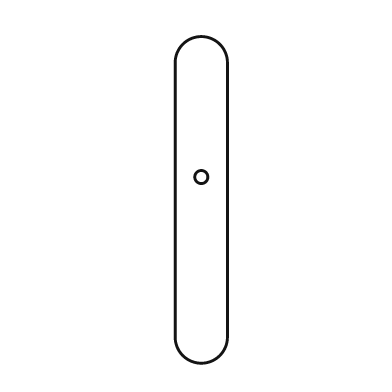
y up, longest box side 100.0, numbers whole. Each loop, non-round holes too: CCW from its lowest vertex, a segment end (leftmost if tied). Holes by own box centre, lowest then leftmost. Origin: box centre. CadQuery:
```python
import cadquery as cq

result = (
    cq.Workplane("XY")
    .moveTo(-8.0, -42.0)
    .threePointArc((0.0, -50.0), (8.0, -42.0))
    .lineTo(8.0, 42.0)
    .threePointArc((0.0, 50.0), (-8.0, 42.0))
    .close()
    .moveTo(0.0, 7.0)
    .circle(2.0)
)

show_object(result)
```